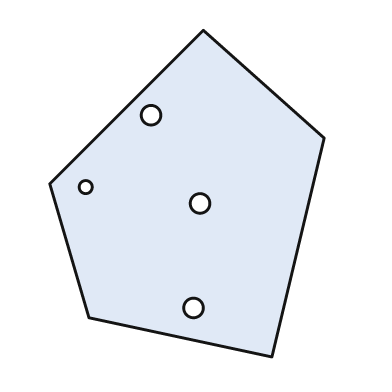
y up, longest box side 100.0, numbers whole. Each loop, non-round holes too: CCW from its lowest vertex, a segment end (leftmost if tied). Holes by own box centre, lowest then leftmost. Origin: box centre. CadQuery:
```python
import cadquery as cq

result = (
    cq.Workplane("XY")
    .moveTo(26.0, -50.0)
    .lineTo(42.0, 17.0)
    .lineTo(5.0, 50.0)
    .lineTo(-42.0, 3.0)
    .lineTo(-30.0, -38.0)
    .close()
    .moveTo(2.0, -35.0)
    .circle(3.0)
    .moveTo(4.0, -3.0)
    .circle(3.0)
    .moveTo(-31.0, 2.0)
    .circle(2.0)
    .moveTo(-11.0, 24.0)
    .circle(3.0)
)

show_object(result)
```